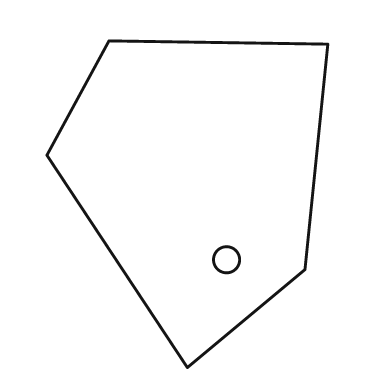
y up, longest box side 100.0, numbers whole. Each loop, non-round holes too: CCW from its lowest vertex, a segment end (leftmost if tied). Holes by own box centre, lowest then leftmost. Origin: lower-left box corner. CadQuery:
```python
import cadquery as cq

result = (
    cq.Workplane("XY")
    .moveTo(43.0, 0.0)
    .lineTo(79.0, 30.0)
    .lineTo(86.0, 99.0)
    .lineTo(19.0, 100.0)
    .lineTo(0.0, 65.0)
    .close()
    .moveTo(55.0, 33.0)
    .circle(4.0)
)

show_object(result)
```